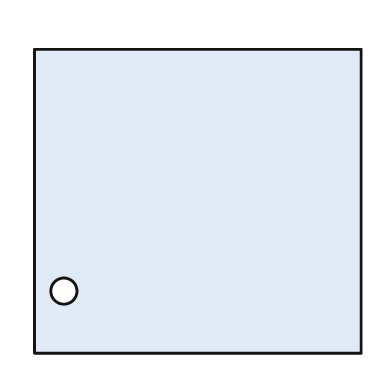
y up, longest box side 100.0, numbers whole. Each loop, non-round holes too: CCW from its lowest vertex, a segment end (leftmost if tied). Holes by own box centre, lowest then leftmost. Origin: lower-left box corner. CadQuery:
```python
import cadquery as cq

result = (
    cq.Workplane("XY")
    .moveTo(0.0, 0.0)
    .lineTo(100.0, 0.0)
    .lineTo(100.0, 93.0)
    .lineTo(0.0, 93.0)
    .close()
    .moveTo(9.0, 19.0)
    .circle(4.0)
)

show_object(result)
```